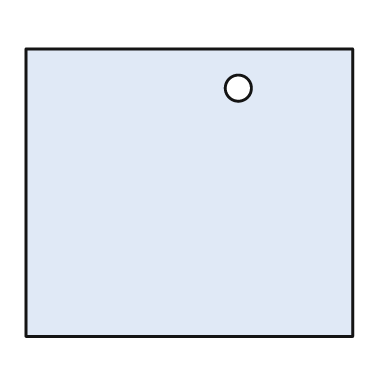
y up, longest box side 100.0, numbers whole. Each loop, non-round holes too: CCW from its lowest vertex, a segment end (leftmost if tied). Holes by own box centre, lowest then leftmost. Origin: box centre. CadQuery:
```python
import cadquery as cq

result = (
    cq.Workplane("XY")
    .moveTo(-50.0, -44.0)
    .lineTo(50.0, -44.0)
    .lineTo(50.0, 44.0)
    .lineTo(-50.0, 44.0)
    .close()
    .moveTo(15.0, 32.0)
    .circle(4.0)
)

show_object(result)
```